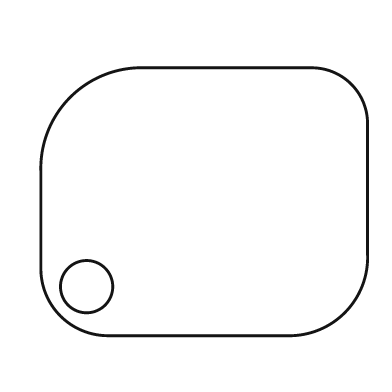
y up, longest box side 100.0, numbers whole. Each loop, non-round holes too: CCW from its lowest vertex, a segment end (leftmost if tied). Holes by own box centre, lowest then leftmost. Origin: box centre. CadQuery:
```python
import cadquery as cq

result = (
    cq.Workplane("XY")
    .moveTo(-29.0, -41.0)
    .lineTo(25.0, -41.0)
    .threePointArc((43.0, -34.0), (50.0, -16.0))
    .lineTo(50.0, 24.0)
    .threePointArc((45.0, 36.0), (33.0, 41.0))
    .lineTo(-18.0, 41.0)
    .threePointArc((-41.0, 32.0), (-50.0, 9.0))
    .lineTo(-50.0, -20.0)
    .threePointArc((-44.0, -35.0), (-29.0, -41.0))
    .close()
    .moveTo(-36.0, -26.0)
    .circle(8.0)
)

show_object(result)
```